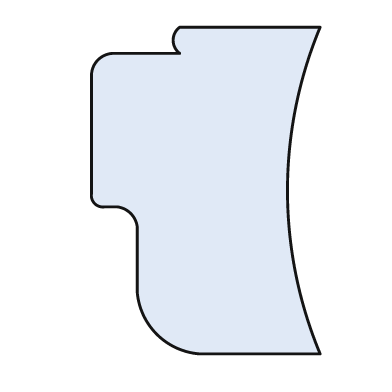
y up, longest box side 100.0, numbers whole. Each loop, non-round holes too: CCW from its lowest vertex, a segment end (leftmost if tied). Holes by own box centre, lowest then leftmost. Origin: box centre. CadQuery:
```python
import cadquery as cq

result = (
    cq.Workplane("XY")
    .moveTo(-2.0, -50.0)
    .lineTo(35.0, -50.0)
    .threePointArc((25.0, 0.0), (35.0, 50.0))
    .lineTo(-8.0, 50.0)
    .threePointArc((-10.0, 46.0), (-8.0, 42.0))
    .lineTo(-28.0, 42.0)
    .threePointArc((-33.0, 40.0), (-35.0, 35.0))
    .lineTo(-35.0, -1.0)
    .threePointArc((-34.0, -4.0), (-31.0, -5.0))
    .lineTo(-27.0, -5.0)
    .threePointArc((-23.0, -7.0), (-21.0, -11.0))
    .lineTo(-21.0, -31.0)
    .threePointArc((-15.0, -44.0), (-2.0, -50.0))
    .close()
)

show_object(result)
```